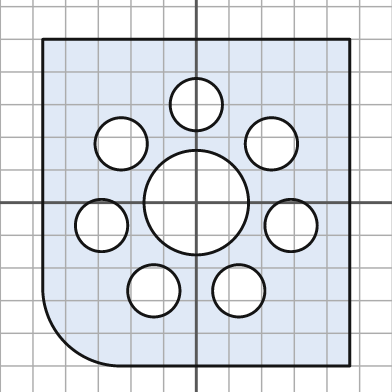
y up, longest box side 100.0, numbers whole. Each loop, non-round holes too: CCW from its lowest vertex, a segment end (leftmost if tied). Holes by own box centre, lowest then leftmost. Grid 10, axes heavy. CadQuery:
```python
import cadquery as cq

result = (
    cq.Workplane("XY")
    .moveTo(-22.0, -50.0)
    .lineTo(47.0, -50.0)
    .lineTo(47.0, 50.0)
    .lineTo(-47.0, 50.0)
    .lineTo(-47.0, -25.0)
    .threePointArc((-40.0, -43.0), (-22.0, -50.0))
    .close()
    .moveTo(-13.0, -27.0)
    .circle(8.0)
    .moveTo(13.0, -27.0)
    .circle(8.0)
    .moveTo(-29.0, -7.0)
    .circle(8.0)
    .moveTo(29.0, -7.0)
    .circle(8.0)
    .moveTo(0.0, 0.0)
    .circle(16.0)
    .moveTo(-23.0, 18.0)
    .circle(8.0)
    .moveTo(23.0, 18.0)
    .circle(8.0)
    .moveTo(0.0, 30.0)
    .circle(8.0)
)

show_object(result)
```